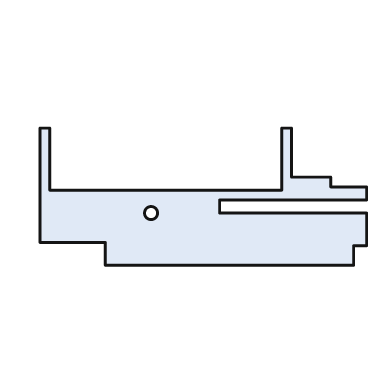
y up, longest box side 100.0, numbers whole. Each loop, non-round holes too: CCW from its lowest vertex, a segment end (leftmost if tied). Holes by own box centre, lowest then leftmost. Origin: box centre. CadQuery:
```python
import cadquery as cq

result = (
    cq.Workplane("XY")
    .moveTo(-30.0, -21.0)
    .lineTo(46.0, -21.0)
    .lineTo(46.0, -15.0)
    .lineTo(50.0, -15.0)
    .lineTo(50.0, -5.0)
    .lineTo(5.0, -5.0)
    .lineTo(5.0, -1.0)
    .lineTo(50.0, -1.0)
    .lineTo(50.0, 3.0)
    .lineTo(39.0, 3.0)
    .lineTo(39.0, 6.0)
    .lineTo(27.0, 6.0)
    .lineTo(27.0, 21.0)
    .lineTo(24.0, 21.0)
    .lineTo(24.0, 2.0)
    .lineTo(-47.0, 2.0)
    .lineTo(-47.0, 21.0)
    .lineTo(-50.0, 21.0)
    .lineTo(-50.0, -14.0)
    .lineTo(-30.0, -14.0)
    .close()
    .moveTo(-16.0, -5.0)
    .circle(2.0)
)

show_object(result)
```